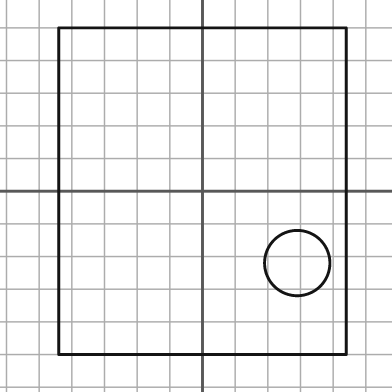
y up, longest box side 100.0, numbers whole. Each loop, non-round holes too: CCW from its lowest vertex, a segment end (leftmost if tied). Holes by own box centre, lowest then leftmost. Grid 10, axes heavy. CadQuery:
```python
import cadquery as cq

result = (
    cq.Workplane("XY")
    .moveTo(-44.0, -50.0)
    .lineTo(44.0, -50.0)
    .lineTo(44.0, 50.0)
    .lineTo(-44.0, 50.0)
    .close()
    .moveTo(29.0, -22.0)
    .circle(10.0)
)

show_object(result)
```